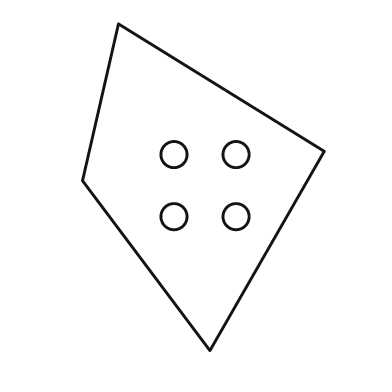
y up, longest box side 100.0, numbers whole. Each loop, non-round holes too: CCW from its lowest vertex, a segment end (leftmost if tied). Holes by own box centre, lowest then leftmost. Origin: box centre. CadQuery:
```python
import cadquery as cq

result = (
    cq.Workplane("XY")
    .moveTo(2.0, -50.0)
    .lineTo(37.0, 11.0)
    .lineTo(-26.0, 50.0)
    .lineTo(-37.0, 2.0)
    .close()
    .moveTo(-9.0, -9.0)
    .circle(4.0)
    .moveTo(10.0, -9.0)
    .circle(4.0)
    .moveTo(-9.0, 10.0)
    .circle(4.0)
    .moveTo(10.0, 10.0)
    .circle(4.0)
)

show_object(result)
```